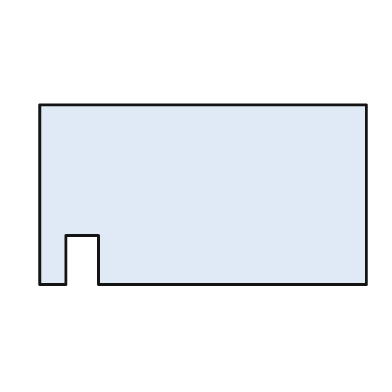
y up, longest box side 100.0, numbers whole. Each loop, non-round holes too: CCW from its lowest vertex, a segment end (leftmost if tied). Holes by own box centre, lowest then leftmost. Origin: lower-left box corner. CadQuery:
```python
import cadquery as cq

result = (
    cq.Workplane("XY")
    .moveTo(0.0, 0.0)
    .lineTo(8.0, 0.0)
    .lineTo(8.0, 15.0)
    .lineTo(18.0, 15.0)
    .lineTo(18.0, 0.0)
    .lineTo(100.0, 0.0)
    .lineTo(100.0, 55.0)
    .lineTo(0.0, 55.0)
    .close()
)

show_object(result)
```